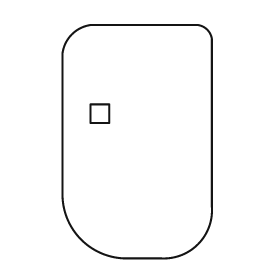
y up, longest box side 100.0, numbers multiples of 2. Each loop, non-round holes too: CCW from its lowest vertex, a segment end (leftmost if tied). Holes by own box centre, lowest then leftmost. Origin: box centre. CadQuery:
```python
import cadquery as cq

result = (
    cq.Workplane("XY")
    .moveTo(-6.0, -50.0)
    .lineTo(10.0, -50.0)
    .threePointArc((26.0, -44.0), (32.0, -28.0))
    .lineTo(32.0, 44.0)
    .threePointArc((30.0, 48.0), (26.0, 50.0))
    .lineTo(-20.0, 50.0)
    .threePointArc((-28.0, 46.0), (-32.0, 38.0))
    .lineTo(-32.0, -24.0)
    .threePointArc((-24.0, -42.0), (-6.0, -50.0))
    .close()
    .moveTo(-20.0, 8.0)
    .lineTo(-12.0, 8.0)
    .lineTo(-12.0, 16.0)
    .lineTo(-20.0, 16.0)
    .close()
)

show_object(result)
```